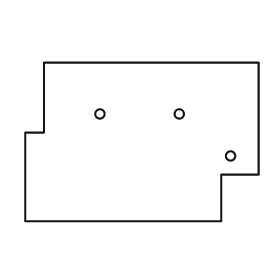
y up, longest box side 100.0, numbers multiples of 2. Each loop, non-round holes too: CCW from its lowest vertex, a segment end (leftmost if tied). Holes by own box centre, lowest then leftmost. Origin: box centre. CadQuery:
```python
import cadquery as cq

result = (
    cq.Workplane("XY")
    .moveTo(-50.0, -34.0)
    .lineTo(34.0, -34.0)
    .lineTo(34.0, -14.0)
    .lineTo(50.0, -14.0)
    .lineTo(50.0, 34.0)
    .lineTo(-42.0, 34.0)
    .lineTo(-42.0, 4.0)
    .lineTo(-50.0, 4.0)
    .close()
    .moveTo(38.0, -6.0)
    .circle(2.0)
    .moveTo(-18.0, 12.0)
    .circle(2.0)
    .moveTo(16.0, 12.0)
    .circle(2.0)
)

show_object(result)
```